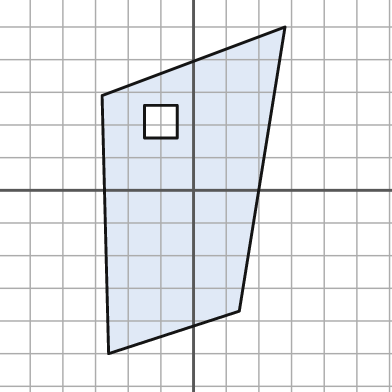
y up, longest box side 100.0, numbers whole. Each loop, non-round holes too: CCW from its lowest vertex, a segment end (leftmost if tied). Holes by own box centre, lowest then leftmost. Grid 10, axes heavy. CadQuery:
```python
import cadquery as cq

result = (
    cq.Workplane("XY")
    .moveTo(-26.0, -50.0)
    .lineTo(14.0, -37.0)
    .lineTo(28.0, 50.0)
    .lineTo(-28.0, 29.0)
    .close()
    .moveTo(-15.0, 16.0)
    .lineTo(-5.0, 16.0)
    .lineTo(-5.0, 26.0)
    .lineTo(-15.0, 26.0)
    .close()
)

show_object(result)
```